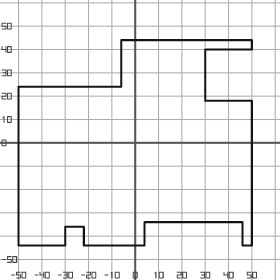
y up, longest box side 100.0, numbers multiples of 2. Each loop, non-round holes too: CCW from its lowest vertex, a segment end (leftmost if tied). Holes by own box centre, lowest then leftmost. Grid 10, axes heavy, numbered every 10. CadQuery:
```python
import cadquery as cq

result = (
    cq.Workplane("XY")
    .moveTo(-50.0, -44.0)
    .lineTo(-30.0, -44.0)
    .lineTo(-30.0, -36.0)
    .lineTo(-22.0, -36.0)
    .lineTo(-22.0, -44.0)
    .lineTo(4.0, -44.0)
    .lineTo(4.0, -34.0)
    .lineTo(46.0, -34.0)
    .lineTo(46.0, -44.0)
    .lineTo(50.0, -44.0)
    .lineTo(50.0, 18.0)
    .lineTo(30.0, 18.0)
    .lineTo(30.0, 40.0)
    .lineTo(50.0, 40.0)
    .lineTo(50.0, 44.0)
    .lineTo(-6.0, 44.0)
    .lineTo(-6.0, 24.0)
    .lineTo(-50.0, 24.0)
    .close()
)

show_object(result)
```